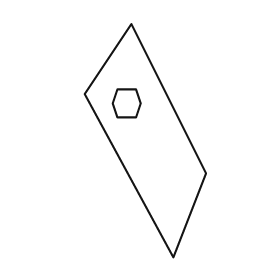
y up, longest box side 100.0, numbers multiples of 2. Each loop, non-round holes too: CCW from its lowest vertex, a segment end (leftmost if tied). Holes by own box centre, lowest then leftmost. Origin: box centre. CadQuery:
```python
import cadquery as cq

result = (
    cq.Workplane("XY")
    .moveTo(12.0, -50.0)
    .lineTo(26.0, -14.0)
    .lineTo(-6.0, 50.0)
    .lineTo(-26.0, 20.0)
    .close()
    .moveTo(-12.0, 10.0)
    .lineTo(-4.0, 10.0)
    .lineTo(-2.0, 16.0)
    .lineTo(-4.0, 22.0)
    .lineTo(-12.0, 22.0)
    .lineTo(-14.0, 16.0)
    .close()
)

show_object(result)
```